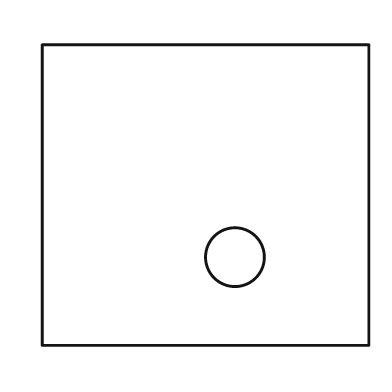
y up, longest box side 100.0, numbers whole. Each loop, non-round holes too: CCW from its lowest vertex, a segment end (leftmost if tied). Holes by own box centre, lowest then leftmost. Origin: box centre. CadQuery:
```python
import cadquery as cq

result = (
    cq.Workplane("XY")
    .moveTo(-50.0, -46.0)
    .lineTo(50.0, -46.0)
    .lineTo(50.0, 46.0)
    .lineTo(-50.0, 46.0)
    .close()
    .moveTo(9.0, -19.0)
    .circle(9.0)
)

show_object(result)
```